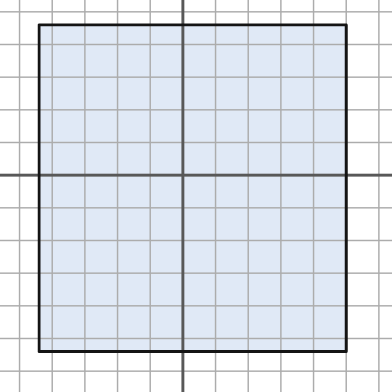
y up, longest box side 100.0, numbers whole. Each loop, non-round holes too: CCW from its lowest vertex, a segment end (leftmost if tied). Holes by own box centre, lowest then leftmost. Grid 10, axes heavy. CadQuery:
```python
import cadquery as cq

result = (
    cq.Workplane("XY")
    .moveTo(-44.0, -54.0)
    .lineTo(50.0, -54.0)
    .lineTo(50.0, 46.0)
    .lineTo(-44.0, 46.0)
    .close()
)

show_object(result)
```